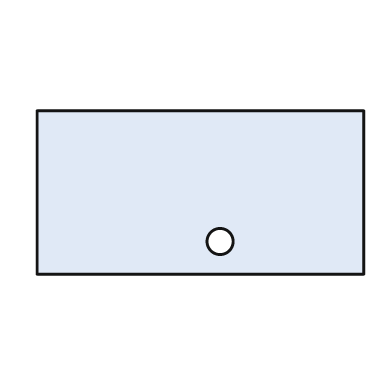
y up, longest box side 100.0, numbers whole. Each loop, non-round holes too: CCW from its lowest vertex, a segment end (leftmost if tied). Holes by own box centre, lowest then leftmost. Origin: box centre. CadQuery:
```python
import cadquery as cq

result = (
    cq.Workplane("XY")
    .moveTo(-50.0, -25.0)
    .lineTo(50.0, -25.0)
    .lineTo(50.0, 25.0)
    .lineTo(-50.0, 25.0)
    .close()
    .moveTo(6.0, -15.0)
    .circle(4.0)
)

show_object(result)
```